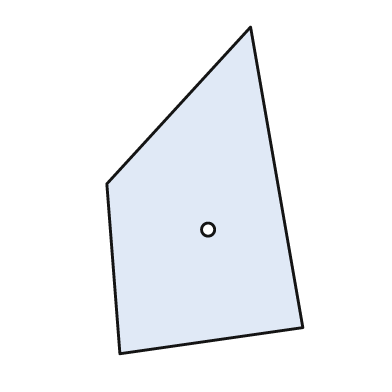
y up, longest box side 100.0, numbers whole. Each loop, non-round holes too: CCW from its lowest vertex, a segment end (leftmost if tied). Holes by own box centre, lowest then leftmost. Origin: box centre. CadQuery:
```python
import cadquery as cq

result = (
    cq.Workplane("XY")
    .moveTo(-26.0, -50.0)
    .lineTo(30.0, -42.0)
    .lineTo(14.0, 50.0)
    .lineTo(-30.0, 2.0)
    .close()
    .moveTo(1.0, -12.0)
    .circle(2.0)
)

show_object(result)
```